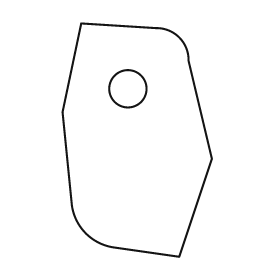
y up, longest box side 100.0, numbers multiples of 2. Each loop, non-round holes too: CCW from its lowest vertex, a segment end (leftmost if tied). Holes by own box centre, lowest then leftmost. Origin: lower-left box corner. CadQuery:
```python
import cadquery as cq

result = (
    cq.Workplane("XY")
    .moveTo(50.0, 0.0)
    .lineTo(64.0, 42.0)
    .lineTo(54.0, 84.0)
    .threePointArc((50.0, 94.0), (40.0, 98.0))
    .lineTo(8.0, 100.0)
    .lineTo(0.0, 62.0)
    .lineTo(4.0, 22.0)
    .threePointArc((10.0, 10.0), (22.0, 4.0))
    .close()
    .moveTo(28.0, 72.0)
    .circle(8.0)
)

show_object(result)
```